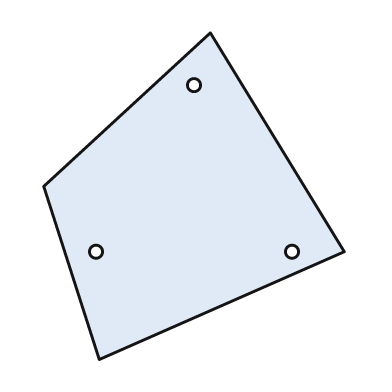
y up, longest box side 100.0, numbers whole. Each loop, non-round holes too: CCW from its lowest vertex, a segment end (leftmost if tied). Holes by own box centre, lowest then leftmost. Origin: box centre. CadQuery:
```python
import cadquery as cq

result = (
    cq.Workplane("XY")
    .moveTo(-29.0, -50.0)
    .lineTo(46.0, -17.0)
    .lineTo(5.0, 50.0)
    .lineTo(-46.0, 3.0)
    .close()
    .moveTo(-30.0, -17.0)
    .circle(2.0)
    .moveTo(30.0, -17.0)
    .circle(2.0)
    .moveTo(0.0, 34.0)
    .circle(2.0)
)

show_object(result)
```